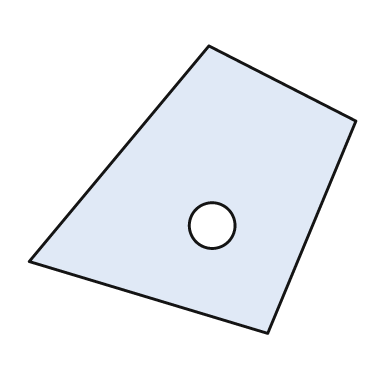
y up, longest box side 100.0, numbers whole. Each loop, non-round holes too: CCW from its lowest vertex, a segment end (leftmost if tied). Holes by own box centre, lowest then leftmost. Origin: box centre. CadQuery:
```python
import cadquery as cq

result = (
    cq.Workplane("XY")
    .moveTo(23.0, -44.0)
    .lineTo(50.0, 21.0)
    .lineTo(5.0, 44.0)
    .lineTo(-50.0, -22.0)
    .close()
    .moveTo(6.0, -11.0)
    .circle(7.0)
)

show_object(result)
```